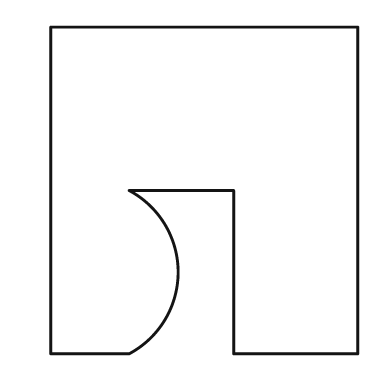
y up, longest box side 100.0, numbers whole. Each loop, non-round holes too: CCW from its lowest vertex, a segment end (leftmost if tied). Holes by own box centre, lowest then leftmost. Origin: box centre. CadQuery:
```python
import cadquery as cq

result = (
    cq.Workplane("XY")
    .moveTo(-47.0, -50.0)
    .lineTo(-23.0, -50.0)
    .threePointArc((-8.0, -25.0), (-23.0, 0.0))
    .lineTo(9.0, 0.0)
    .lineTo(9.0, -50.0)
    .lineTo(47.0, -50.0)
    .lineTo(47.0, 50.0)
    .lineTo(-47.0, 50.0)
    .close()
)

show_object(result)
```